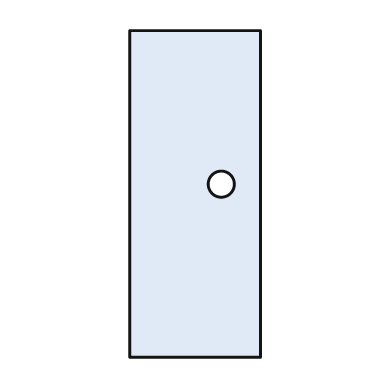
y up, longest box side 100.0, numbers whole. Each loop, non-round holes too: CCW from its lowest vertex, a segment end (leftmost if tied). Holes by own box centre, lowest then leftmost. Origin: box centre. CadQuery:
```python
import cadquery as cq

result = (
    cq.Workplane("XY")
    .moveTo(-20.0, -50.0)
    .lineTo(20.0, -50.0)
    .lineTo(20.0, 50.0)
    .lineTo(-20.0, 50.0)
    .close()
    .moveTo(8.0, 3.0)
    .circle(4.0)
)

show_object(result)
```